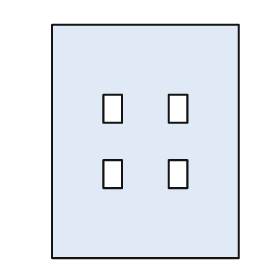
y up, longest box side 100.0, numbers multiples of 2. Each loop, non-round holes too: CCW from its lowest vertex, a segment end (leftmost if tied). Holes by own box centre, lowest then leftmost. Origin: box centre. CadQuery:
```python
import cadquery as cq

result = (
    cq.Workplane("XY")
    .moveTo(-40.0, -50.0)
    .lineTo(40.0, -50.0)
    .lineTo(40.0, 50.0)
    .lineTo(-40.0, 50.0)
    .close()
    .moveTo(-18.0, -20.0)
    .lineTo(-10.0, -20.0)
    .lineTo(-10.0, -8.0)
    .lineTo(-18.0, -8.0)
    .close()
    .moveTo(10.0, -20.0)
    .lineTo(18.0, -20.0)
    .lineTo(18.0, -8.0)
    .lineTo(10.0, -8.0)
    .close()
    .moveTo(-18.0, 8.0)
    .lineTo(-10.0, 8.0)
    .lineTo(-10.0, 20.0)
    .lineTo(-18.0, 20.0)
    .close()
    .moveTo(10.0, 8.0)
    .lineTo(18.0, 8.0)
    .lineTo(18.0, 20.0)
    .lineTo(10.0, 20.0)
    .close()
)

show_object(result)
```